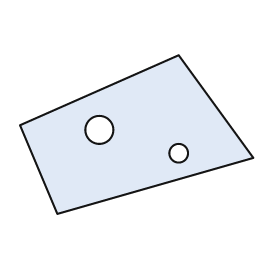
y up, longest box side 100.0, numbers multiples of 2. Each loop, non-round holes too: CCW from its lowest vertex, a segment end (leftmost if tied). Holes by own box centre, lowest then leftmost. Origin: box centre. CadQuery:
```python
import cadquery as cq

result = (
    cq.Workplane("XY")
    .moveTo(-34.0, -34.0)
    .lineTo(50.0, -10.0)
    .lineTo(18.0, 34.0)
    .lineTo(-50.0, 4.0)
    .close()
    .moveTo(18.0, -8.0)
    .circle(4.0)
    .moveTo(-16.0, 2.0)
    .circle(6.0)
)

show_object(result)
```